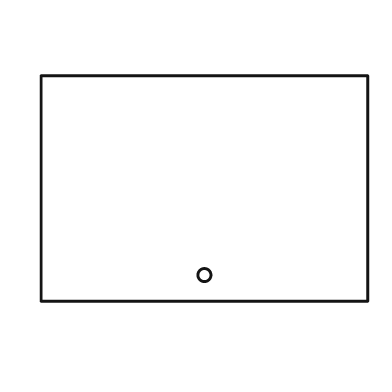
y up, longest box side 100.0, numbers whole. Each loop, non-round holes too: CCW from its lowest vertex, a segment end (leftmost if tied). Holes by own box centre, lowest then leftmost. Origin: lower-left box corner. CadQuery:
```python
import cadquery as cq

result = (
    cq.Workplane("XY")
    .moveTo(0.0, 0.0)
    .lineTo(100.0, 0.0)
    .lineTo(100.0, 69.0)
    .lineTo(0.0, 69.0)
    .close()
    .moveTo(50.0, 8.0)
    .circle(2.0)
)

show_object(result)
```